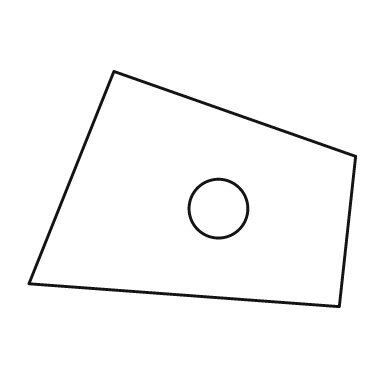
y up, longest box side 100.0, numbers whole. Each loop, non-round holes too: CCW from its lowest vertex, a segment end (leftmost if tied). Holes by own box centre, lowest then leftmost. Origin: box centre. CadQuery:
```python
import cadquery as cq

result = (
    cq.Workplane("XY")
    .moveTo(45.0, -36.0)
    .lineTo(50.0, 10.0)
    .lineTo(-24.0, 36.0)
    .lineTo(-50.0, -29.0)
    .close()
    .moveTo(8.0, -6.0)
    .circle(9.0)
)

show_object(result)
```